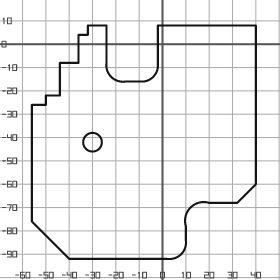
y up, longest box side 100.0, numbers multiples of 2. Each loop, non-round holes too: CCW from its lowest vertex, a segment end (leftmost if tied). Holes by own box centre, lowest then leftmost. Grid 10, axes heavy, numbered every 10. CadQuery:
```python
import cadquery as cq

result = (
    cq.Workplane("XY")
    .moveTo(-40.0, -92.0)
    .lineTo(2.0, -92.0)
    .threePointArc((8.0, -90.0), (10.0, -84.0))
    .lineTo(10.0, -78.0)
    .threePointArc((12.0, -70.0), (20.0, -68.0))
    .lineTo(32.0, -68.0)
    .lineTo(40.0, -60.0)
    .lineTo(40.0, 8.0)
    .lineTo(-2.0, 8.0)
    .lineTo(-2.0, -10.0)
    .threePointArc((-4.0, -14.0), (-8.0, -16.0))
    .lineTo(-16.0, -16.0)
    .threePointArc((-22.0, -14.0), (-24.0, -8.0))
    .lineTo(-24.0, 8.0)
    .lineTo(-32.0, 8.0)
    .lineTo(-32.0, 4.0)
    .lineTo(-36.0, 4.0)
    .lineTo(-36.0, -8.0)
    .lineTo(-44.0, -8.0)
    .lineTo(-44.0, -22.0)
    .lineTo(-50.0, -22.0)
    .lineTo(-50.0, -26.0)
    .lineTo(-56.0, -26.0)
    .lineTo(-56.0, -76.0)
    .close()
    .moveTo(-30.0, -42.0)
    .circle(4.0)
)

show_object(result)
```